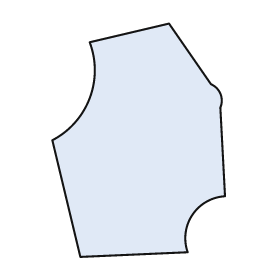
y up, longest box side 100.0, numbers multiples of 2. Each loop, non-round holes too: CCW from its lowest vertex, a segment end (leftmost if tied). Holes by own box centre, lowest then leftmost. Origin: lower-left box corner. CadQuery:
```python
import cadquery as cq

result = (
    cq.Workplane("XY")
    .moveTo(12.0, 0.0)
    .lineTo(58.0, 2.0)
    .threePointArc((60.0, 18.0), (74.0, 26.0))
    .lineTo(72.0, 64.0)
    .threePointArc((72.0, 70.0), (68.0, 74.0))
    .lineTo(50.0, 100.0)
    .lineTo(16.0, 92.0)
    .threePointArc((16.0, 68.0), (0.0, 50.0))
    .close()
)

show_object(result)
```